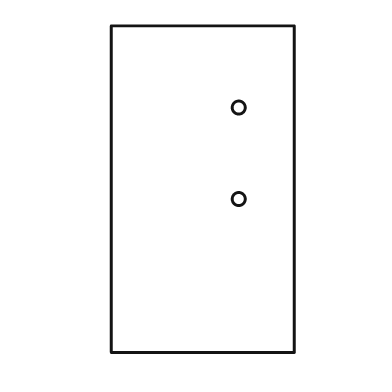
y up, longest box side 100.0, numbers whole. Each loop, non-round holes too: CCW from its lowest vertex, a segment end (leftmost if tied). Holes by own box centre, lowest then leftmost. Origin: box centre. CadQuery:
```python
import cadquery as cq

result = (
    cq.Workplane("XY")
    .moveTo(-28.0, -50.0)
    .lineTo(28.0, -50.0)
    .lineTo(28.0, 50.0)
    .lineTo(-28.0, 50.0)
    .close()
    .moveTo(11.0, -3.0)
    .circle(2.0)
    .moveTo(11.0, 25.0)
    .circle(2.0)
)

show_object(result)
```